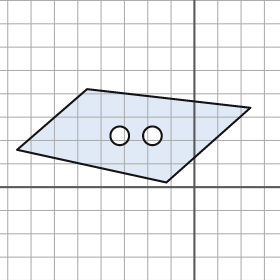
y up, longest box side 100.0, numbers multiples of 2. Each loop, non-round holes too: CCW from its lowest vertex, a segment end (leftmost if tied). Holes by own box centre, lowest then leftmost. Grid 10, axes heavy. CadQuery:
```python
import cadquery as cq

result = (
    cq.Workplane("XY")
    .moveTo(-12.0, 2.0)
    .lineTo(24.0, 34.0)
    .lineTo(-46.0, 42.0)
    .lineTo(-76.0, 16.0)
    .close()
    .moveTo(-32.0, 22.0)
    .circle(4.0)
    .moveTo(-18.0, 22.0)
    .circle(4.0)
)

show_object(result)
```